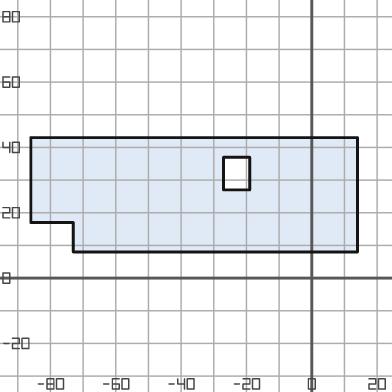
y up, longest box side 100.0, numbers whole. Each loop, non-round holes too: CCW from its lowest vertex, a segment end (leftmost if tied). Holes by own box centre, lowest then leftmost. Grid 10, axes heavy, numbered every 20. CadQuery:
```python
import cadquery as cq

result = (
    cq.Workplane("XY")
    .moveTo(-73.0, 8.0)
    .lineTo(14.0, 8.0)
    .lineTo(14.0, 43.0)
    .lineTo(-86.0, 43.0)
    .lineTo(-86.0, 17.0)
    .lineTo(-73.0, 17.0)
    .close()
    .moveTo(-27.0, 27.0)
    .lineTo(-19.0, 27.0)
    .lineTo(-19.0, 37.0)
    .lineTo(-27.0, 37.0)
    .close()
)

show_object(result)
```